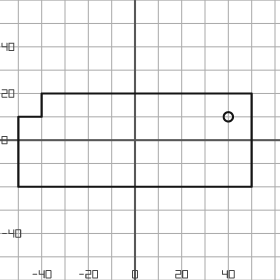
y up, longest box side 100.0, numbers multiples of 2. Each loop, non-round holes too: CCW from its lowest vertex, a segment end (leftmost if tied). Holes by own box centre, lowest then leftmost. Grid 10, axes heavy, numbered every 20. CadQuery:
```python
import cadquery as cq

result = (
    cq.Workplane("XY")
    .moveTo(-50.0, -20.0)
    .lineTo(50.0, -20.0)
    .lineTo(50.0, 20.0)
    .lineTo(-40.0, 20.0)
    .lineTo(-40.0, 10.0)
    .lineTo(-50.0, 10.0)
    .close()
    .moveTo(40.0, 10.0)
    .circle(2.0)
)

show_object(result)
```